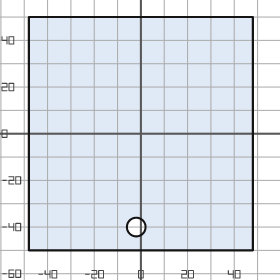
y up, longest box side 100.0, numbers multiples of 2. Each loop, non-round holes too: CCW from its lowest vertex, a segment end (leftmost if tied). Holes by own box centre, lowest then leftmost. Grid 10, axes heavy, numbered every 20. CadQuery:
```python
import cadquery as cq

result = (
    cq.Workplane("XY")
    .moveTo(-48.0, -50.0)
    .lineTo(48.0, -50.0)
    .lineTo(48.0, 50.0)
    .lineTo(-48.0, 50.0)
    .close()
    .moveTo(-2.0, -40.0)
    .circle(4.0)
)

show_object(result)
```